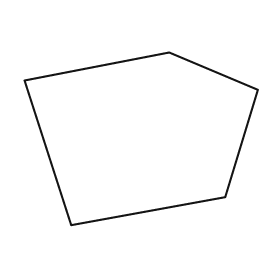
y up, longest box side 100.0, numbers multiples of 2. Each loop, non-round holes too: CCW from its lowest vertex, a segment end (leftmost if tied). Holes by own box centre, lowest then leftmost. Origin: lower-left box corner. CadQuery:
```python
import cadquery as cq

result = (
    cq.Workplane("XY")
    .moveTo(20.0, 0.0)
    .lineTo(86.0, 12.0)
    .lineTo(100.0, 58.0)
    .lineTo(62.0, 74.0)
    .lineTo(0.0, 62.0)
    .close()
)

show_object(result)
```